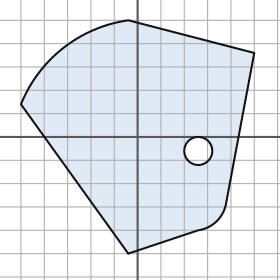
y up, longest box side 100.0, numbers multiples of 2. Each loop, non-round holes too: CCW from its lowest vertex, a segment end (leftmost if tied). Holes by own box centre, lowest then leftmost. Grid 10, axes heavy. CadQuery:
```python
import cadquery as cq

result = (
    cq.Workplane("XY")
    .moveTo(-4.0, -50.0)
    .lineTo(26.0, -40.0)
    .threePointArc((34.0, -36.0), (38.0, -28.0))
    .lineTo(50.0, 36.0)
    .lineTo(-4.0, 50.0)
    .threePointArc((-32.0, 38.0), (-50.0, 14.0))
    .close()
    .moveTo(26.0, -6.0)
    .circle(6.0)
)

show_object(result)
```